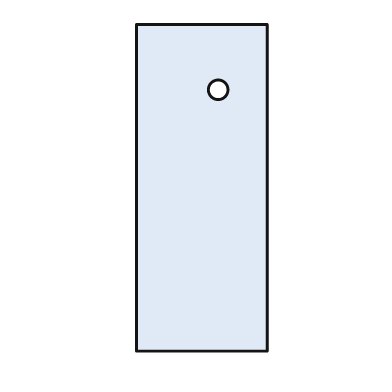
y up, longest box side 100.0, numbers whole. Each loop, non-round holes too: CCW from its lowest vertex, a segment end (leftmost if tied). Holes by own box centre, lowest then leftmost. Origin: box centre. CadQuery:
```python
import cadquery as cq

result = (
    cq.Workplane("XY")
    .moveTo(-20.0, -50.0)
    .lineTo(20.0, -50.0)
    .lineTo(20.0, 50.0)
    .lineTo(-20.0, 50.0)
    .close()
    .moveTo(5.0, 30.0)
    .circle(3.0)
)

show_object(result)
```